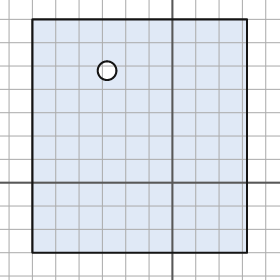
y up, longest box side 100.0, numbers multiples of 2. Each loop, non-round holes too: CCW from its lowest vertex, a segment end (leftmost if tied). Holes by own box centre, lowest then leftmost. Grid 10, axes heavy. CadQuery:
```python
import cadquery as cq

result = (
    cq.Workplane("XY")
    .moveTo(-60.0, -30.0)
    .lineTo(32.0, -30.0)
    .lineTo(32.0, 70.0)
    .lineTo(-60.0, 70.0)
    .close()
    .moveTo(-28.0, 48.0)
    .circle(4.0)
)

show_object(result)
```